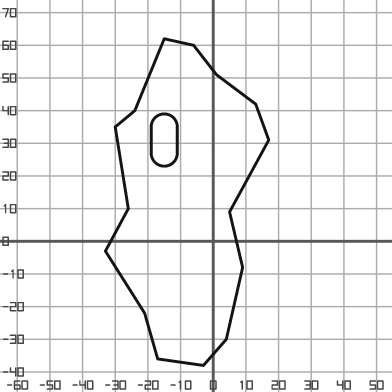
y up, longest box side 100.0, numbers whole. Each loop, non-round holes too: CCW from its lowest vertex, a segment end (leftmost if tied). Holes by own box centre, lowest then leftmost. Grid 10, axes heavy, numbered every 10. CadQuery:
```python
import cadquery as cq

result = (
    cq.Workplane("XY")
    .moveTo(-3.0, -38.0)
    .lineTo(4.0, -30.0)
    .lineTo(9.0, -8.0)
    .lineTo(5.0, 9.0)
    .lineTo(17.0, 31.0)
    .lineTo(13.0, 42.0)
    .lineTo(1.0, 51.0)
    .lineTo(-6.0, 60.0)
    .lineTo(-15.0, 62.0)
    .lineTo(-24.0, 40.0)
    .lineTo(-30.0, 35.0)
    .lineTo(-26.0, 10.0)
    .lineTo(-33.0, -3.0)
    .lineTo(-21.0, -22.0)
    .lineTo(-17.0, -36.0)
    .close()
    .moveTo(-19.0, 27.0)
    .threePointArc((-15.0, 23.0), (-11.0, 27.0))
    .lineTo(-11.0, 35.0)
    .threePointArc((-15.0, 39.0), (-19.0, 35.0))
    .close()
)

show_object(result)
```